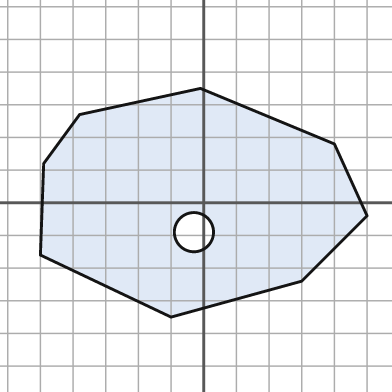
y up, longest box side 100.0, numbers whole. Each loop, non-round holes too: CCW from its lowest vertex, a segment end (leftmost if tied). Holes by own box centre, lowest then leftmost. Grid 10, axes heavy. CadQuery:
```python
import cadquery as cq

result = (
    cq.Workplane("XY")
    .moveTo(-10.0, -35.0)
    .lineTo(30.0, -24.0)
    .lineTo(50.0, -4.0)
    .lineTo(40.0, 18.0)
    .lineTo(-1.0, 35.0)
    .lineTo(-38.0, 27.0)
    .lineTo(-49.0, 12.0)
    .lineTo(-50.0, -16.0)
    .close()
    .moveTo(-3.0, -9.0)
    .circle(6.0)
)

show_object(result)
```